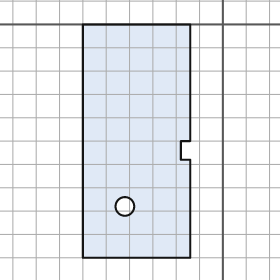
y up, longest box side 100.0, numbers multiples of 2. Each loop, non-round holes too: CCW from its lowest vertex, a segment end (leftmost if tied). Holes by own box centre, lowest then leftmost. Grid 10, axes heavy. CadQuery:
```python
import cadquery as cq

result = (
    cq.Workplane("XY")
    .moveTo(-60.0, -100.0)
    .lineTo(-14.0, -100.0)
    .lineTo(-14.0, -58.0)
    .lineTo(-18.0, -58.0)
    .lineTo(-18.0, -50.0)
    .lineTo(-14.0, -50.0)
    .lineTo(-14.0, 0.0)
    .lineTo(-60.0, 0.0)
    .close()
    .moveTo(-42.0, -78.0)
    .circle(4.0)
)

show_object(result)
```